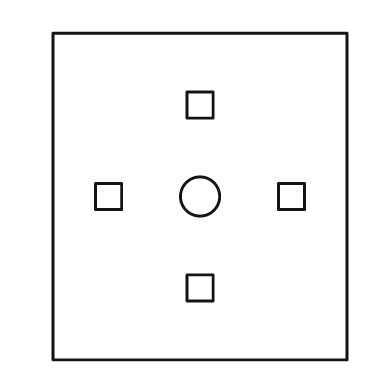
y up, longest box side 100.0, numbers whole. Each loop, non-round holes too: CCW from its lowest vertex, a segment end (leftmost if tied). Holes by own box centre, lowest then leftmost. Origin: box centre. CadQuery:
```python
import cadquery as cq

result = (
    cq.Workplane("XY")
    .moveTo(-45.0, -50.0)
    .lineTo(45.0, -50.0)
    .lineTo(45.0, 50.0)
    .lineTo(-45.0, 50.0)
    .close()
    .moveTo(-4.0, -32.0)
    .lineTo(4.0, -32.0)
    .lineTo(4.0, -24.0)
    .lineTo(-4.0, -24.0)
    .close()
    .moveTo(-32.0, -4.0)
    .lineTo(-24.0, -4.0)
    .lineTo(-24.0, 4.0)
    .lineTo(-32.0, 4.0)
    .close()
    .moveTo(0.0, 0.0)
    .circle(6.0)
    .moveTo(24.0, -4.0)
    .lineTo(32.0, -4.0)
    .lineTo(32.0, 4.0)
    .lineTo(24.0, 4.0)
    .close()
    .moveTo(-4.0, 24.0)
    .lineTo(4.0, 24.0)
    .lineTo(4.0, 32.0)
    .lineTo(-4.0, 32.0)
    .close()
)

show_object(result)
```